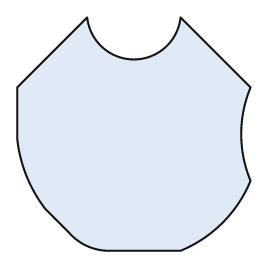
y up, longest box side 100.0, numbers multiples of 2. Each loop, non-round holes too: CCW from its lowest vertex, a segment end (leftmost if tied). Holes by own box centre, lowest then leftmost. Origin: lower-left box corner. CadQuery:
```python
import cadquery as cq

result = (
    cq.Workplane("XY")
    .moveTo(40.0, 0.0)
    .lineTo(70.0, 0.0)
    .threePointArc((88.0, 12.0), (100.0, 30.0))
    .threePointArc((96.0, 50.0), (100.0, 70.0))
    .lineTo(70.0, 100.0)
    .threePointArc((50.0, 82.0), (30.0, 100.0))
    .lineTo(0.0, 70.0)
    .lineTo(0.0, 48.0)
    .threePointArc((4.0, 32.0), (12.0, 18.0))
    .lineTo(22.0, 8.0)
    .threePointArc((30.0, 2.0), (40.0, 0.0))
    .close()
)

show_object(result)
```